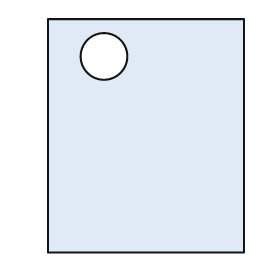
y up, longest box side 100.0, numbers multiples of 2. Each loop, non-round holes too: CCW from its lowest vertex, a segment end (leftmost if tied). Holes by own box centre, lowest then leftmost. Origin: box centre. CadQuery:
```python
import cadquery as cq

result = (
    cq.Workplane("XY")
    .moveTo(-42.0, -50.0)
    .lineTo(42.0, -50.0)
    .lineTo(42.0, 50.0)
    .lineTo(-42.0, 50.0)
    .close()
    .moveTo(-18.0, 34.0)
    .circle(10.0)
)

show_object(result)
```